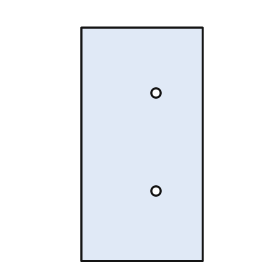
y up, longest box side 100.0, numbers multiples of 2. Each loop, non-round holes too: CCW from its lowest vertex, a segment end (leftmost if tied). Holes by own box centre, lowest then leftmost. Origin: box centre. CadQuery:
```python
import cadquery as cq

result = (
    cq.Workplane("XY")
    .moveTo(-26.0, -50.0)
    .lineTo(26.0, -50.0)
    .lineTo(26.0, 50.0)
    .lineTo(-26.0, 50.0)
    .close()
    .moveTo(6.0, -20.0)
    .circle(2.0)
    .moveTo(6.0, 22.0)
    .circle(2.0)
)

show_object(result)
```